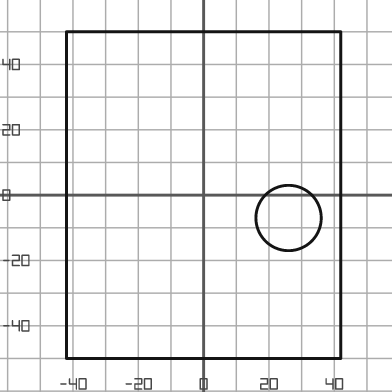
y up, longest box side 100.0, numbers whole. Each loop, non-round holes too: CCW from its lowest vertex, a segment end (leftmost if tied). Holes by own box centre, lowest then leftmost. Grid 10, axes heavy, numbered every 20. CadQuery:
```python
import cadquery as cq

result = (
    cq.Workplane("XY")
    .moveTo(-42.0, -50.0)
    .lineTo(42.0, -50.0)
    .lineTo(42.0, 50.0)
    .lineTo(-42.0, 50.0)
    .close()
    .moveTo(26.0, -7.0)
    .circle(10.0)
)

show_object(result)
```